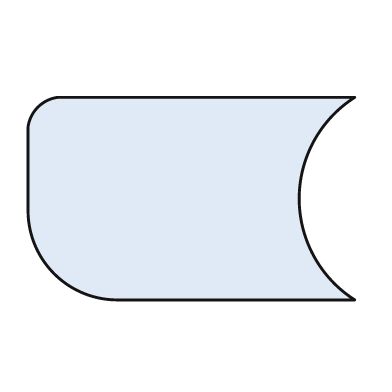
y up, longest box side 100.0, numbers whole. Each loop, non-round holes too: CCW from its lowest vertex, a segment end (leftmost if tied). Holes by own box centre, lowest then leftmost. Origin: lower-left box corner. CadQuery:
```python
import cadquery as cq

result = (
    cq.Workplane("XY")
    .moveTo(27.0, 0.0)
    .lineTo(100.0, 0.0)
    .threePointArc((83.0, 31.0), (100.0, 62.0))
    .lineTo(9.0, 62.0)
    .threePointArc((3.0, 59.0), (0.0, 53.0))
    .lineTo(0.0, 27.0)
    .threePointArc((8.0, 8.0), (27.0, 0.0))
    .close()
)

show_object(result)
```